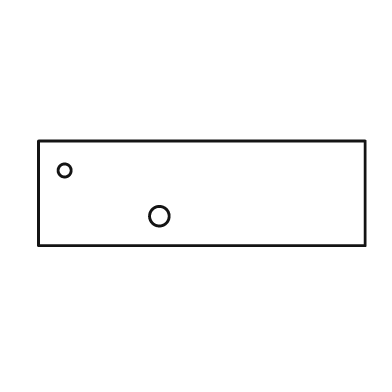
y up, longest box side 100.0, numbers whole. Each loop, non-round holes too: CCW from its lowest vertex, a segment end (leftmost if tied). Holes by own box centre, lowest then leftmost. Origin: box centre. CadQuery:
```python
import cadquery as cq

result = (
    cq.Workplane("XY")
    .moveTo(-50.0, -16.0)
    .lineTo(50.0, -16.0)
    .lineTo(50.0, 16.0)
    .lineTo(-50.0, 16.0)
    .close()
    .moveTo(-13.0, -7.0)
    .circle(3.0)
    .moveTo(-42.0, 7.0)
    .circle(2.0)
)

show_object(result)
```